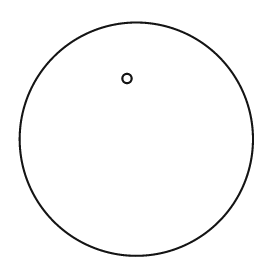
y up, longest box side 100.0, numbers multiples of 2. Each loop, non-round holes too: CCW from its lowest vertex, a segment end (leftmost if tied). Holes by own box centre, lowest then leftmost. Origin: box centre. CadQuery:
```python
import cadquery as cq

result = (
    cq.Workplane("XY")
    .moveTo(0.0, 0.0)
    .circle(50.0)
    .moveTo(-4.0, 26.0)
    .circle(2.0)
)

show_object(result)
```